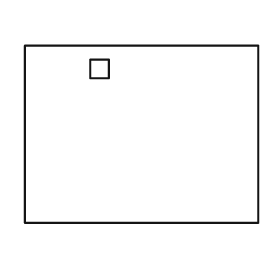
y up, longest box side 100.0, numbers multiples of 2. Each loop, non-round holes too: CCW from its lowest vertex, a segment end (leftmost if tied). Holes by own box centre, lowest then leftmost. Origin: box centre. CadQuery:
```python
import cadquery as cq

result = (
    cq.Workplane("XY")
    .moveTo(-50.0, -38.0)
    .lineTo(50.0, -38.0)
    .lineTo(50.0, 38.0)
    .lineTo(-50.0, 38.0)
    .close()
    .moveTo(-22.0, 24.0)
    .lineTo(-14.0, 24.0)
    .lineTo(-14.0, 32.0)
    .lineTo(-22.0, 32.0)
    .close()
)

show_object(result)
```